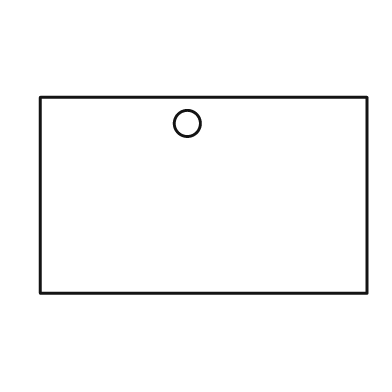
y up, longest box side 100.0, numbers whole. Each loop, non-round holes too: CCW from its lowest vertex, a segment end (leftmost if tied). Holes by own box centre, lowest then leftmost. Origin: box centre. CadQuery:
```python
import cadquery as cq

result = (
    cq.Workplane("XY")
    .moveTo(-50.0, -30.0)
    .lineTo(50.0, -30.0)
    .lineTo(50.0, 30.0)
    .lineTo(-50.0, 30.0)
    .close()
    .moveTo(-5.0, 22.0)
    .circle(4.0)
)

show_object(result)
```